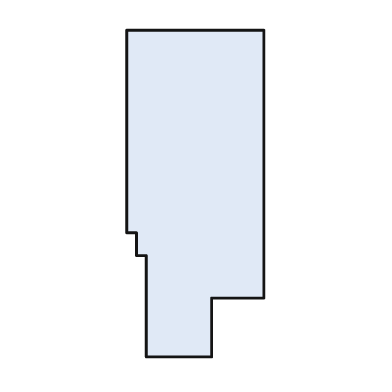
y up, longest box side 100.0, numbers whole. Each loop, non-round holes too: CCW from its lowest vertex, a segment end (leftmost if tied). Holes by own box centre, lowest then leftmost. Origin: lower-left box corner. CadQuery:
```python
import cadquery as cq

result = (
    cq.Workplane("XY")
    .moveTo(6.0, 0.0)
    .lineTo(26.0, 0.0)
    .lineTo(26.0, 18.0)
    .lineTo(42.0, 18.0)
    .lineTo(42.0, 100.0)
    .lineTo(0.0, 100.0)
    .lineTo(0.0, 38.0)
    .lineTo(3.0, 38.0)
    .lineTo(3.0, 31.0)
    .lineTo(6.0, 31.0)
    .close()
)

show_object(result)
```